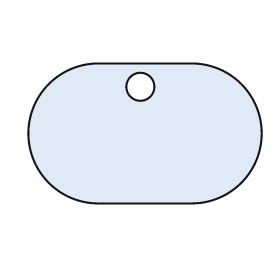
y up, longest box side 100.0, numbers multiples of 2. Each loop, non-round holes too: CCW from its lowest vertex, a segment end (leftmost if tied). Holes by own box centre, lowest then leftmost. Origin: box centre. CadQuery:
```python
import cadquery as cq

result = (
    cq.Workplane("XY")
    .moveTo(-20.0, -30.0)
    .lineTo(20.0, -30.0)
    .threePointArc((50.0, 0.0), (20.0, 30.0))
    .lineTo(-20.0, 30.0)
    .threePointArc((-50.0, 0.0), (-20.0, -30.0))
    .close()
    .moveTo(-2.0, 20.0)
    .circle(6.0)
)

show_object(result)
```